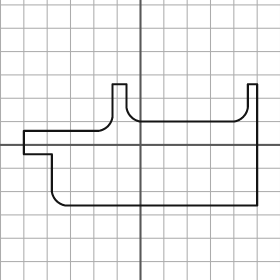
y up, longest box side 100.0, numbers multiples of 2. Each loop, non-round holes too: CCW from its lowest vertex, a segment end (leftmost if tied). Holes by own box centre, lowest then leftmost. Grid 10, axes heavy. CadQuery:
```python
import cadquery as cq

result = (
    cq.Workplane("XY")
    .moveTo(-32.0, -26.0)
    .lineTo(50.0, -26.0)
    .lineTo(50.0, 26.0)
    .lineTo(46.0, 26.0)
    .lineTo(46.0, 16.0)
    .threePointArc((44.0, 12.0), (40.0, 10.0))
    .lineTo(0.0, 10.0)
    .threePointArc((-4.0, 12.0), (-6.0, 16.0))
    .lineTo(-6.0, 26.0)
    .lineTo(-12.0, 26.0)
    .lineTo(-12.0, 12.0)
    .threePointArc((-14.0, 8.0), (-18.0, 6.0))
    .lineTo(-50.0, 6.0)
    .lineTo(-50.0, -4.0)
    .lineTo(-38.0, -4.0)
    .lineTo(-38.0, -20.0)
    .threePointArc((-36.0, -24.0), (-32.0, -26.0))
    .close()
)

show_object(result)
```